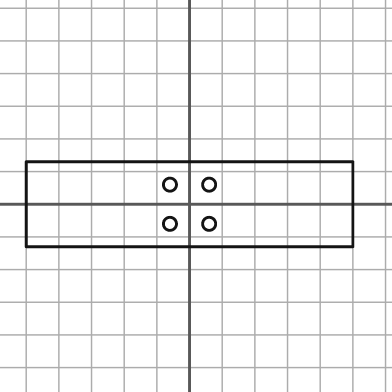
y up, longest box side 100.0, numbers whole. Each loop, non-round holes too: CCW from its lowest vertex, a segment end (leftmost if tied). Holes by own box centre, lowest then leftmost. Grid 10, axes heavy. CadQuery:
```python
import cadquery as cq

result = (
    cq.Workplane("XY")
    .moveTo(-50.0, -13.0)
    .lineTo(50.0, -13.0)
    .lineTo(50.0, 13.0)
    .lineTo(-50.0, 13.0)
    .close()
    .moveTo(-6.0, -6.0)
    .circle(2.0)
    .moveTo(6.0, -6.0)
    .circle(2.0)
    .moveTo(-6.0, 6.0)
    .circle(2.0)
    .moveTo(6.0, 6.0)
    .circle(2.0)
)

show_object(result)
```